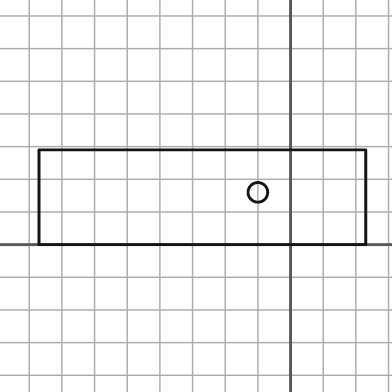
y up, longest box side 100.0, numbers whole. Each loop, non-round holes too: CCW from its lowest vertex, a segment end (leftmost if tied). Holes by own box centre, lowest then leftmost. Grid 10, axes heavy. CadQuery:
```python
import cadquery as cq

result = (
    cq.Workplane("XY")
    .moveTo(-77.0, 0.0)
    .lineTo(23.0, 0.0)
    .lineTo(23.0, 29.0)
    .lineTo(-77.0, 29.0)
    .close()
    .moveTo(-10.0, 16.0)
    .circle(3.0)
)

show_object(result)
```